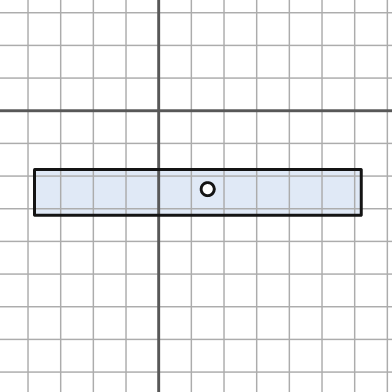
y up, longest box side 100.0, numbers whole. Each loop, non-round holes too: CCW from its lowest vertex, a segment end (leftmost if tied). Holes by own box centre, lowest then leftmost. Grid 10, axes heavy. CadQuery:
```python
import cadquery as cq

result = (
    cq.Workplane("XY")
    .moveTo(-38.0, -32.0)
    .lineTo(62.0, -32.0)
    .lineTo(62.0, -18.0)
    .lineTo(-38.0, -18.0)
    .close()
    .moveTo(15.0, -24.0)
    .circle(2.0)
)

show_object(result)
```